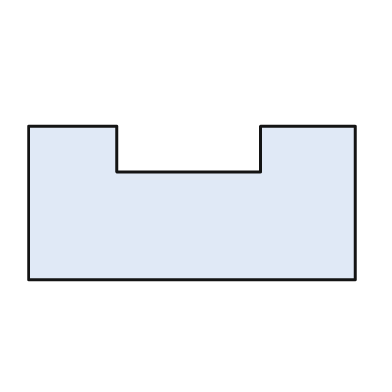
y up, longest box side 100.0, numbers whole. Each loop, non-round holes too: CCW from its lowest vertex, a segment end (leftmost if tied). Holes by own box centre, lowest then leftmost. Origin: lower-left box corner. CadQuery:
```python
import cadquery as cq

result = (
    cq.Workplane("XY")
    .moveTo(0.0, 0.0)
    .lineTo(100.0, 0.0)
    .lineTo(100.0, 47.0)
    .lineTo(71.0, 47.0)
    .lineTo(71.0, 33.0)
    .lineTo(27.0, 33.0)
    .lineTo(27.0, 47.0)
    .lineTo(0.0, 47.0)
    .close()
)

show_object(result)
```